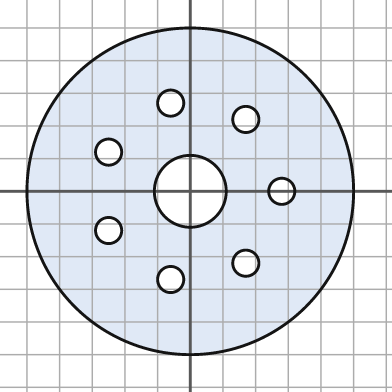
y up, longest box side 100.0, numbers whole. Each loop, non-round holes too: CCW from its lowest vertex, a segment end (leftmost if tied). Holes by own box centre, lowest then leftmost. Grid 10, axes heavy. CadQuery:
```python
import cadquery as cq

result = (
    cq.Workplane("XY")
    .moveTo(0.0, 0.0)
    .circle(50.0)
    .moveTo(-6.0, -27.0)
    .circle(4.0)
    .moveTo(17.0, -22.0)
    .circle(4.0)
    .moveTo(-25.0, -12.0)
    .circle(4.0)
    .moveTo(0.0, 0.0)
    .circle(11.0)
    .moveTo(28.0, 0.0)
    .circle(4.0)
    .moveTo(-25.0, 12.0)
    .circle(4.0)
    .moveTo(17.0, 22.0)
    .circle(4.0)
    .moveTo(-6.0, 27.0)
    .circle(4.0)
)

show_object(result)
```